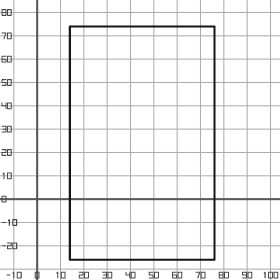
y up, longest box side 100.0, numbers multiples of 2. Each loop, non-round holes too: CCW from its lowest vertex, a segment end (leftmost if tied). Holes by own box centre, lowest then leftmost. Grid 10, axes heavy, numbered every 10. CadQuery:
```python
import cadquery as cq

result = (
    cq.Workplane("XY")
    .moveTo(14.0, -26.0)
    .lineTo(76.0, -26.0)
    .lineTo(76.0, 74.0)
    .lineTo(14.0, 74.0)
    .close()
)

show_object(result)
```